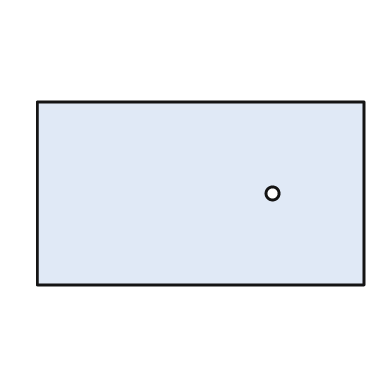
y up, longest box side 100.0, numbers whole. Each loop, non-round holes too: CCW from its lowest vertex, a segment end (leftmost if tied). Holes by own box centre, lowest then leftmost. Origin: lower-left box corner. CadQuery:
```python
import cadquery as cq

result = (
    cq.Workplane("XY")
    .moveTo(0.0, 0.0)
    .lineTo(100.0, 0.0)
    .lineTo(100.0, 56.0)
    .lineTo(0.0, 56.0)
    .close()
    .moveTo(72.0, 28.0)
    .circle(2.0)
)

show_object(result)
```